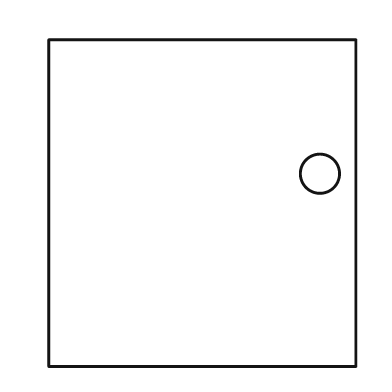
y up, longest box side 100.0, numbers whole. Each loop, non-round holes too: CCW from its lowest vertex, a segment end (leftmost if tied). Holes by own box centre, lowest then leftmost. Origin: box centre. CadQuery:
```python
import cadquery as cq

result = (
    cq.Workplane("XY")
    .moveTo(-47.0, -50.0)
    .lineTo(47.0, -50.0)
    .lineTo(47.0, 50.0)
    .lineTo(-47.0, 50.0)
    .close()
    .moveTo(36.0, 9.0)
    .circle(6.0)
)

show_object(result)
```